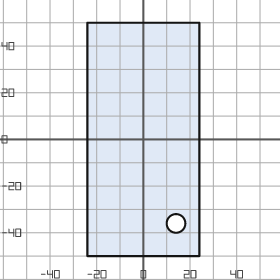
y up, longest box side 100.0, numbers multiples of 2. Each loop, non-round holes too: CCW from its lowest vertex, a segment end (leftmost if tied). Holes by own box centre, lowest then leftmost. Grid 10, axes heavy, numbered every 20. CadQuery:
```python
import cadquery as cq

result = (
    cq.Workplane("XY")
    .moveTo(-24.0, -50.0)
    .lineTo(24.0, -50.0)
    .lineTo(24.0, 50.0)
    .lineTo(-24.0, 50.0)
    .close()
    .moveTo(14.0, -36.0)
    .circle(4.0)
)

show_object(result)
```